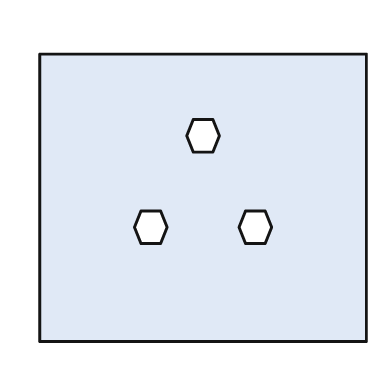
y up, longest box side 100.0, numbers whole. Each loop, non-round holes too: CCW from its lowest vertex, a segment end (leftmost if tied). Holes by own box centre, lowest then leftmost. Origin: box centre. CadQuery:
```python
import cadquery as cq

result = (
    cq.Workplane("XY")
    .moveTo(-50.0, -44.0)
    .lineTo(50.0, -44.0)
    .lineTo(50.0, 44.0)
    .lineTo(-50.0, 44.0)
    .close()
    .moveTo(-19.0, -14.0)
    .lineTo(-13.0, -14.0)
    .lineTo(-11.0, -9.0)
    .lineTo(-13.0, -4.0)
    .lineTo(-19.0, -4.0)
    .lineTo(-21.0, -9.0)
    .close()
    .moveTo(13.0, -14.0)
    .lineTo(19.0, -14.0)
    .lineTo(21.0, -9.0)
    .lineTo(19.0, -4.0)
    .lineTo(13.0, -4.0)
    .lineTo(11.0, -9.0)
    .close()
    .moveTo(-3.0, 14.0)
    .lineTo(3.0, 14.0)
    .lineTo(5.0, 19.0)
    .lineTo(3.0, 24.0)
    .lineTo(-3.0, 24.0)
    .lineTo(-5.0, 19.0)
    .close()
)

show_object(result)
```